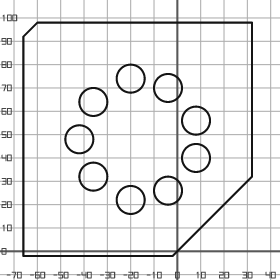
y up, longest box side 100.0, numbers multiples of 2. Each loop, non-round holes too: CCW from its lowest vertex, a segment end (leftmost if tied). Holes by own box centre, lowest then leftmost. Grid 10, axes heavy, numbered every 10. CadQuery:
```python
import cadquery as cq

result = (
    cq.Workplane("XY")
    .moveTo(-66.0, -2.0)
    .lineTo(-2.0, -2.0)
    .lineTo(32.0, 32.0)
    .lineTo(32.0, 98.0)
    .lineTo(-60.0, 98.0)
    .lineTo(-66.0, 92.0)
    .close()
    .moveTo(-20.0, 22.0)
    .circle(6.0)
    .moveTo(-4.0, 26.0)
    .circle(6.0)
    .moveTo(-36.0, 32.0)
    .circle(6.0)
    .moveTo(8.0, 40.0)
    .circle(6.0)
    .moveTo(-42.0, 48.0)
    .circle(6.0)
    .moveTo(8.0, 56.0)
    .circle(6.0)
    .moveTo(-36.0, 64.0)
    .circle(6.0)
    .moveTo(-4.0, 70.0)
    .circle(6.0)
    .moveTo(-20.0, 74.0)
    .circle(6.0)
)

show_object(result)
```